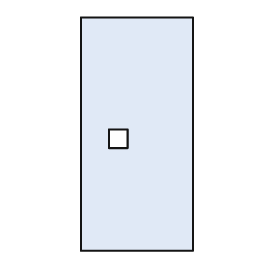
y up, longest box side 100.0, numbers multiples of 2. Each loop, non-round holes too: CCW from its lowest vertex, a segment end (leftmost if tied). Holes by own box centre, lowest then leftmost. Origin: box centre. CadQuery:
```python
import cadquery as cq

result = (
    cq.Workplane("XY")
    .moveTo(-24.0, -50.0)
    .lineTo(24.0, -50.0)
    .lineTo(24.0, 50.0)
    .lineTo(-24.0, 50.0)
    .close()
    .moveTo(-12.0, -6.0)
    .lineTo(-4.0, -6.0)
    .lineTo(-4.0, 2.0)
    .lineTo(-12.0, 2.0)
    .close()
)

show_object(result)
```